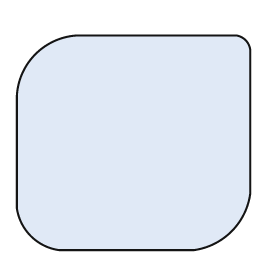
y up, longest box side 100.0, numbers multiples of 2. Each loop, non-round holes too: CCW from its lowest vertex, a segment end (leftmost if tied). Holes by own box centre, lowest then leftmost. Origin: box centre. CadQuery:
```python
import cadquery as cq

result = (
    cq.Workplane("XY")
    .moveTo(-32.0, -46.0)
    .lineTo(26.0, -46.0)
    .threePointArc((42.0, -38.0), (50.0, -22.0))
    .lineTo(50.0, 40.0)
    .threePointArc((48.0, 44.0), (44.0, 46.0))
    .lineTo(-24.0, 46.0)
    .threePointArc((-42.0, 38.0), (-50.0, 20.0))
    .lineTo(-50.0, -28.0)
    .threePointArc((-44.0, -40.0), (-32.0, -46.0))
    .close()
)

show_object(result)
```